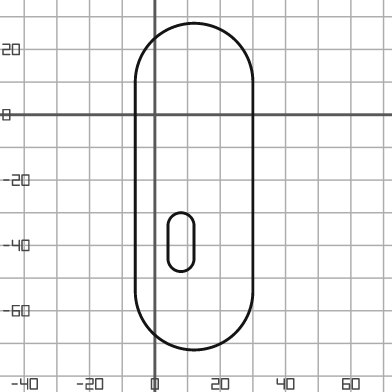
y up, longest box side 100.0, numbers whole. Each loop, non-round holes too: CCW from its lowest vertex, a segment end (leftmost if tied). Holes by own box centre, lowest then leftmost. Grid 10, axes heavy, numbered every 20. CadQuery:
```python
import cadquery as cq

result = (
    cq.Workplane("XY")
    .moveTo(-6.0, -54.0)
    .threePointArc((12.0, -72.0), (30.0, -54.0))
    .lineTo(30.0, 10.0)
    .threePointArc((12.0, 28.0), (-6.0, 10.0))
    .close()
    .moveTo(4.0, -44.0)
    .threePointArc((8.0, -48.0), (12.0, -44.0))
    .lineTo(12.0, -34.0)
    .threePointArc((8.0, -30.0), (4.0, -34.0))
    .close()
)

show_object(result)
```